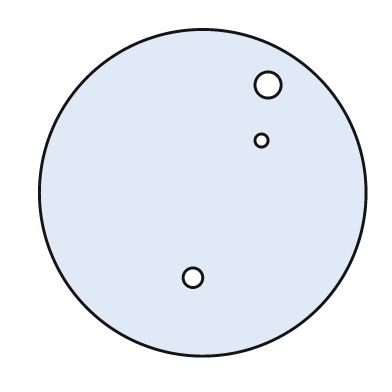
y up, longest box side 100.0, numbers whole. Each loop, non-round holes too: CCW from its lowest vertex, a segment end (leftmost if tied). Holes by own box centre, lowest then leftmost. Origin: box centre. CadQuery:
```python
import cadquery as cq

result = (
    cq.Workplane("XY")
    .moveTo(0.0, 0.0)
    .circle(50.0)
    .moveTo(-3.0, -26.0)
    .circle(3.0)
    .moveTo(18.0, 16.0)
    .circle(2.0)
    .moveTo(20.0, 33.0)
    .circle(4.0)
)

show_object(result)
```